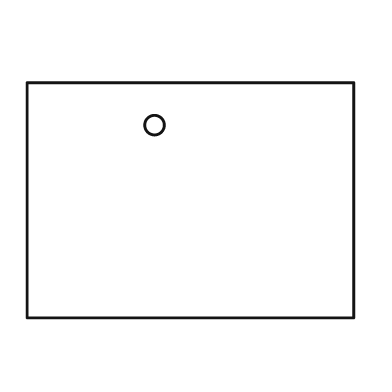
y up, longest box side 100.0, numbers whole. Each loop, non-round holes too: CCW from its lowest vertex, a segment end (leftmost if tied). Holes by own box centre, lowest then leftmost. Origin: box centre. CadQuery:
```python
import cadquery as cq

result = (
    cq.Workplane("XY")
    .moveTo(-50.0, -36.0)
    .lineTo(50.0, -36.0)
    .lineTo(50.0, 36.0)
    .lineTo(-50.0, 36.0)
    .close()
    .moveTo(-11.0, 23.0)
    .circle(3.0)
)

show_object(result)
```